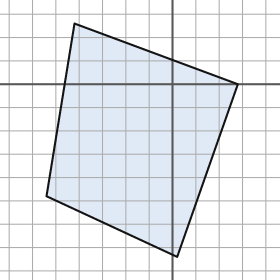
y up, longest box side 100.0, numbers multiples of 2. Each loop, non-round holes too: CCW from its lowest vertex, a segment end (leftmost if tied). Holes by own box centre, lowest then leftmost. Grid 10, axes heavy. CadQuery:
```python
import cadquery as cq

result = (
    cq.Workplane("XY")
    .moveTo(2.0, -74.0)
    .lineTo(28.0, 0.0)
    .lineTo(-42.0, 26.0)
    .lineTo(-54.0, -48.0)
    .close()
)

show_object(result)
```